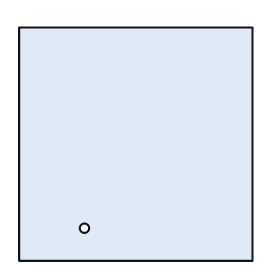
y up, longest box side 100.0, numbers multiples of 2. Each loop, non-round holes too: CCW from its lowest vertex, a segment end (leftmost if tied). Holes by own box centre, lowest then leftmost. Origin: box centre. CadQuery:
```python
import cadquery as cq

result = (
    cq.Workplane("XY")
    .moveTo(-50.0, -50.0)
    .lineTo(50.0, -50.0)
    .lineTo(50.0, 50.0)
    .lineTo(-50.0, 50.0)
    .close()
    .moveTo(-22.0, -36.0)
    .circle(2.0)
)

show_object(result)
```